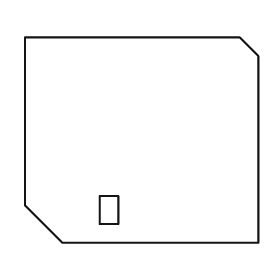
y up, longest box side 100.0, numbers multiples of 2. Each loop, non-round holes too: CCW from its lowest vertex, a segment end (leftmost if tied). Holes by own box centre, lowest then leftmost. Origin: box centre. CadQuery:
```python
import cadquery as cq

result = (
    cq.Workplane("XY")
    .moveTo(-34.0, -44.0)
    .lineTo(50.0, -44.0)
    .lineTo(50.0, 36.0)
    .lineTo(42.0, 44.0)
    .lineTo(-50.0, 44.0)
    .lineTo(-50.0, -28.0)
    .close()
    .moveTo(-18.0, -36.0)
    .lineTo(-10.0, -36.0)
    .lineTo(-10.0, -24.0)
    .lineTo(-18.0, -24.0)
    .close()
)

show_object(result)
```